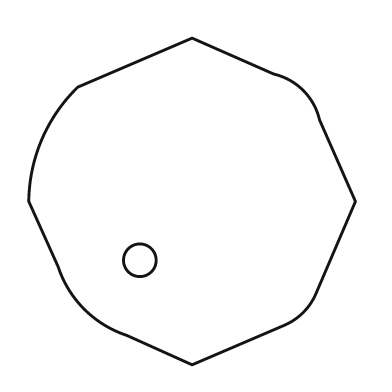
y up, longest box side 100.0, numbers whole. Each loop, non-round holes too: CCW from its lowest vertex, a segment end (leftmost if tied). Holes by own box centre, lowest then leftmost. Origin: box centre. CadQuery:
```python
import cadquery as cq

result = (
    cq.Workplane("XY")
    .moveTo(0.0, -50.0)
    .lineTo(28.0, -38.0)
    .threePointArc((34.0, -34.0), (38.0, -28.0))
    .lineTo(50.0, 0.0)
    .lineTo(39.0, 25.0)
    .threePointArc((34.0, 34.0), (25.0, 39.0))
    .lineTo(0.0, 50.0)
    .lineTo(-35.0, 35.0)
    .threePointArc((-46.0, 19.0), (-50.0, 0.0))
    .lineTo(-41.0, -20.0)
    .threePointArc((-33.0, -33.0), (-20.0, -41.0))
    .close()
    .moveTo(-16.0, -18.0)
    .circle(5.0)
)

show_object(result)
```